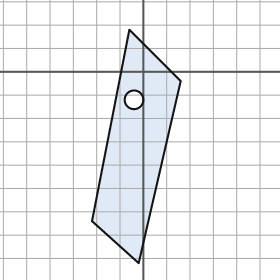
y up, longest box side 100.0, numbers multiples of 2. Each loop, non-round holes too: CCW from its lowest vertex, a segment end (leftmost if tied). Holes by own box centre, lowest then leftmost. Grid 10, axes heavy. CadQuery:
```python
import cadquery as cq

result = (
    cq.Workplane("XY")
    .moveTo(-2.0, -82.0)
    .lineTo(16.0, -4.0)
    .lineTo(-6.0, 18.0)
    .lineTo(-22.0, -64.0)
    .close()
    .moveTo(-4.0, -12.0)
    .circle(4.0)
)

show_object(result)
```